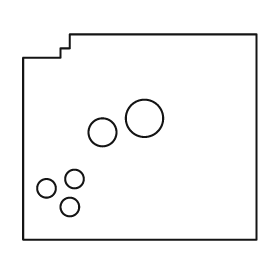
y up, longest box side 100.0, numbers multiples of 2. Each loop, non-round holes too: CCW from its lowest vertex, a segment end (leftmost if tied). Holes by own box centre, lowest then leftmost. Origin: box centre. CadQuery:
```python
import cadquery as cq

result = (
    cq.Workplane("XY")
    .moveTo(-50.0, -44.0)
    .lineTo(50.0, -44.0)
    .lineTo(50.0, 44.0)
    .lineTo(-30.0, 44.0)
    .lineTo(-30.0, 38.0)
    .lineTo(-34.0, 38.0)
    .lineTo(-34.0, 34.0)
    .lineTo(-50.0, 34.0)
    .close()
    .moveTo(-30.0, -30.0)
    .circle(4.0)
    .moveTo(-40.0, -22.0)
    .circle(4.0)
    .moveTo(-28.0, -18.0)
    .circle(4.0)
    .moveTo(-16.0, 2.0)
    .circle(6.0)
    .moveTo(2.0, 8.0)
    .circle(8.0)
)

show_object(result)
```